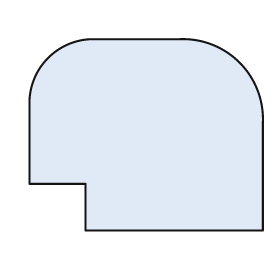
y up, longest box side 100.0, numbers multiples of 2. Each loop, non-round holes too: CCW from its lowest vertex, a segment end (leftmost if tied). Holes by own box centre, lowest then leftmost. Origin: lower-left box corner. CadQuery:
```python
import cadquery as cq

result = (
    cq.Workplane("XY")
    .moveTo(24.0, 0.0)
    .lineTo(100.0, 0.0)
    .lineTo(100.0, 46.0)
    .threePointArc((90.0, 72.0), (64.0, 82.0))
    .lineTo(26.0, 82.0)
    .threePointArc((8.0, 74.0), (0.0, 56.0))
    .lineTo(0.0, 20.0)
    .lineTo(24.0, 20.0)
    .close()
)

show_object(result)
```